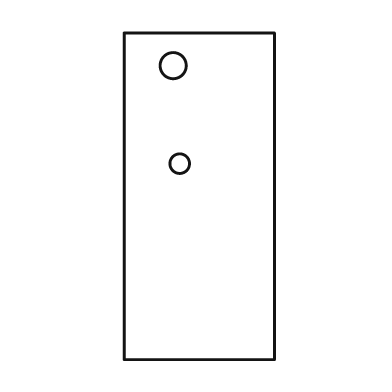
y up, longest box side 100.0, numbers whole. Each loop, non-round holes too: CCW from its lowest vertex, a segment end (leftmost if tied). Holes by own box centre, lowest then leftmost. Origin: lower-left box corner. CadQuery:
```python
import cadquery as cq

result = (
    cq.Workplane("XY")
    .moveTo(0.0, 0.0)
    .lineTo(46.0, 0.0)
    .lineTo(46.0, 100.0)
    .lineTo(0.0, 100.0)
    .close()
    .moveTo(17.0, 60.0)
    .circle(3.0)
    .moveTo(15.0, 90.0)
    .circle(4.0)
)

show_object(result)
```